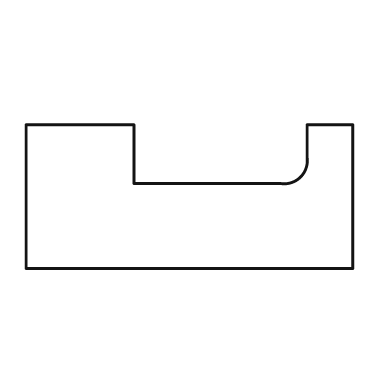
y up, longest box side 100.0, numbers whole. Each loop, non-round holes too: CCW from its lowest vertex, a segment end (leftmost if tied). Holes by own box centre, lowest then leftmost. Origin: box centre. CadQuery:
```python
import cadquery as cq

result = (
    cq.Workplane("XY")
    .moveTo(-50.0, -22.0)
    .lineTo(50.0, -22.0)
    .lineTo(50.0, 22.0)
    .lineTo(36.0, 22.0)
    .lineTo(36.0, 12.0)
    .threePointArc((34.0, 6.0), (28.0, 4.0))
    .lineTo(-17.0, 4.0)
    .lineTo(-17.0, 22.0)
    .lineTo(-50.0, 22.0)
    .close()
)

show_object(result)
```